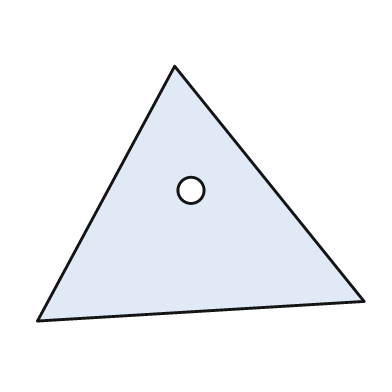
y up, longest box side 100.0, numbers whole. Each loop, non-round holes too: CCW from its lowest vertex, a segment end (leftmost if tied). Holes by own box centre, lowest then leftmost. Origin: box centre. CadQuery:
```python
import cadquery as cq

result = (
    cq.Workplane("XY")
    .moveTo(-50.0, -39.0)
    .lineTo(50.0, -33.0)
    .lineTo(-8.0, 39.0)
    .close()
    .moveTo(-3.0, 1.0)
    .circle(4.0)
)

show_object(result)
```